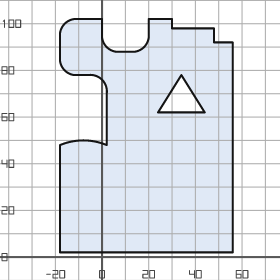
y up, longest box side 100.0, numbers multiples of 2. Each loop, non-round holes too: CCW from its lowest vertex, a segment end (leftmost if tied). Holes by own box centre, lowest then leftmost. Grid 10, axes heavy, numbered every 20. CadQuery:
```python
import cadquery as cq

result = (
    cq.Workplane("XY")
    .moveTo(-18.0, 2.0)
    .lineTo(56.0, 2.0)
    .lineTo(56.0, 92.0)
    .lineTo(48.0, 92.0)
    .lineTo(48.0, 98.0)
    .lineTo(30.0, 98.0)
    .lineTo(30.0, 102.0)
    .lineTo(20.0, 102.0)
    .lineTo(20.0, 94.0)
    .threePointArc((18.0, 90.0), (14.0, 88.0))
    .lineTo(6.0, 88.0)
    .threePointArc((2.0, 90.0), (0.0, 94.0))
    .lineTo(0.0, 102.0)
    .lineTo(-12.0, 102.0)
    .threePointArc((-16.0, 100.0), (-18.0, 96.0))
    .lineTo(-18.0, 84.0)
    .threePointArc((-16.0, 80.0), (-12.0, 78.0))
    .lineTo(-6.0, 78.0)
    .threePointArc((0.0, 76.0), (2.0, 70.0))
    .lineTo(2.0, 48.0)
    .threePointArc((-8.0, 50.0), (-18.0, 48.0))
    .close()
    .moveTo(24.0, 62.0)
    .lineTo(44.0, 62.0)
    .lineTo(34.0, 78.0)
    .close()
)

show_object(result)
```